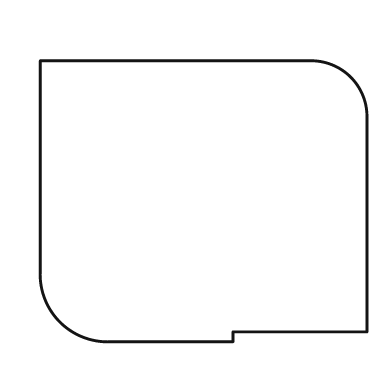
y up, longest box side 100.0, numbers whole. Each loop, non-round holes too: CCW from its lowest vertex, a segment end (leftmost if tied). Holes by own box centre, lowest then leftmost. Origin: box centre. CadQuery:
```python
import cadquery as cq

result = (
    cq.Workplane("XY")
    .moveTo(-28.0, -43.0)
    .lineTo(9.0, -43.0)
    .lineTo(9.0, -40.0)
    .lineTo(50.0, -40.0)
    .lineTo(50.0, 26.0)
    .threePointArc((45.0, 38.0), (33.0, 43.0))
    .lineTo(-50.0, 43.0)
    .lineTo(-50.0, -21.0)
    .threePointArc((-44.0, -37.0), (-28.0, -43.0))
    .close()
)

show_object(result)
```